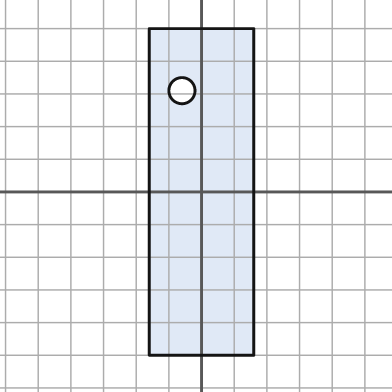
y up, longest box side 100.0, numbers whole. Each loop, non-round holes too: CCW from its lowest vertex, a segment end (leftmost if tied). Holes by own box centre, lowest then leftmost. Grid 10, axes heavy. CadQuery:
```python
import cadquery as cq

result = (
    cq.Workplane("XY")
    .moveTo(-16.0, -50.0)
    .lineTo(16.0, -50.0)
    .lineTo(16.0, 50.0)
    .lineTo(-16.0, 50.0)
    .close()
    .moveTo(-6.0, 31.0)
    .circle(4.0)
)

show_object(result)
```